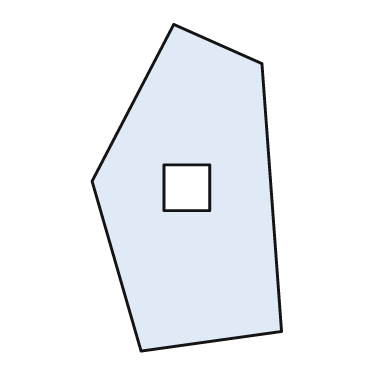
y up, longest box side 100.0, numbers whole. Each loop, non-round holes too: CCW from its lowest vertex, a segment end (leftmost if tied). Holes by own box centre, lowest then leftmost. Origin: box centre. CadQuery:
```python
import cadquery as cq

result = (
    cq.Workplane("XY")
    .moveTo(-14.0, -50.0)
    .lineTo(29.0, -44.0)
    .lineTo(23.0, 38.0)
    .lineTo(-4.0, 50.0)
    .lineTo(-29.0, 2.0)
    .close()
    .moveTo(-7.0, -7.0)
    .lineTo(7.0, -7.0)
    .lineTo(7.0, 7.0)
    .lineTo(-7.0, 7.0)
    .close()
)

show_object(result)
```